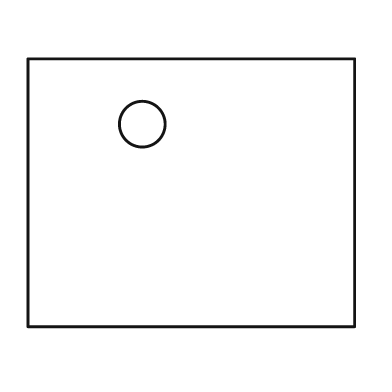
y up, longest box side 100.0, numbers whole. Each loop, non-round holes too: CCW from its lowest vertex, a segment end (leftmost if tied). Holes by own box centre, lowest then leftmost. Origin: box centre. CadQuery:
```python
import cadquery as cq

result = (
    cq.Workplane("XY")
    .moveTo(-50.0, -41.0)
    .lineTo(50.0, -41.0)
    .lineTo(50.0, 41.0)
    .lineTo(-50.0, 41.0)
    .close()
    .moveTo(-15.0, 21.0)
    .circle(7.0)
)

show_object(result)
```